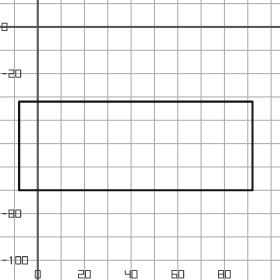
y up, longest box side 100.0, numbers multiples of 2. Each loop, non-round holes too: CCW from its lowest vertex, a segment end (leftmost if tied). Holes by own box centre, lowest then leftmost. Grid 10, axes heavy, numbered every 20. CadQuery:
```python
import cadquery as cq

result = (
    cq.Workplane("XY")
    .moveTo(-8.0, -70.0)
    .lineTo(92.0, -70.0)
    .lineTo(92.0, -32.0)
    .lineTo(-8.0, -32.0)
    .close()
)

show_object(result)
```